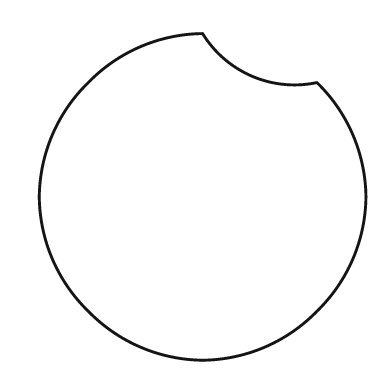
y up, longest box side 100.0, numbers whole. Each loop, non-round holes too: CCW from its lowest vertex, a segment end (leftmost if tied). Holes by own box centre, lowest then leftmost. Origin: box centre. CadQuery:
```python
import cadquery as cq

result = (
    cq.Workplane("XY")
    .moveTo(0.0, -50.0)
    .threePointArc((19.0, -46.0), (35.0, -35.0))
    .threePointArc((46.0, -19.0), (50.0, 0.0))
    .threePointArc((46.0, 19.0), (35.0, 35.0))
    .threePointArc((15.0, 37.0), (0.0, 50.0))
    .threePointArc((-19.0, 46.0), (-35.0, 35.0))
    .threePointArc((-46.0, 19.0), (-50.0, 0.0))
    .threePointArc((-46.0, -19.0), (-35.0, -35.0))
    .threePointArc((-19.0, -46.0), (0.0, -50.0))
    .close()
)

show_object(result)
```